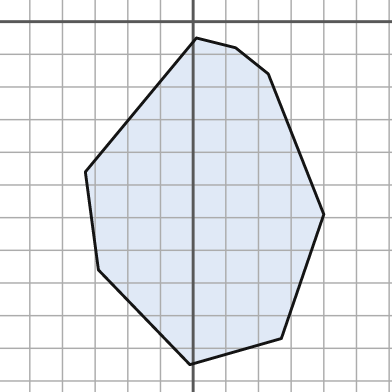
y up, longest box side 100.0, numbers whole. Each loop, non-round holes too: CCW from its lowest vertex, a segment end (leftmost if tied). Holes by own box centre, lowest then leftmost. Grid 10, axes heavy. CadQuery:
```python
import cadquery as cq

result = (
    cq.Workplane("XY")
    .moveTo(-1.0, -105.0)
    .lineTo(27.0, -97.0)
    .lineTo(40.0, -59.0)
    .lineTo(23.0, -16.0)
    .lineTo(13.0, -8.0)
    .lineTo(1.0, -5.0)
    .lineTo(-33.0, -46.0)
    .lineTo(-29.0, -76.0)
    .close()
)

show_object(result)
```